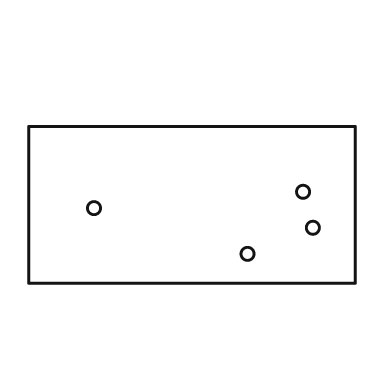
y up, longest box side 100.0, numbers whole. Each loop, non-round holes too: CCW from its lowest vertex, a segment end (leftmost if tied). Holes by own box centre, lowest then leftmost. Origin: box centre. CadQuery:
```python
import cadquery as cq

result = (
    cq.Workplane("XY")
    .moveTo(-50.0, -24.0)
    .lineTo(50.0, -24.0)
    .lineTo(50.0, 24.0)
    .lineTo(-50.0, 24.0)
    .close()
    .moveTo(17.0, -15.0)
    .circle(2.0)
    .moveTo(37.0, -7.0)
    .circle(2.0)
    .moveTo(-30.0, -1.0)
    .circle(2.0)
    .moveTo(34.0, 4.0)
    .circle(2.0)
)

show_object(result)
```